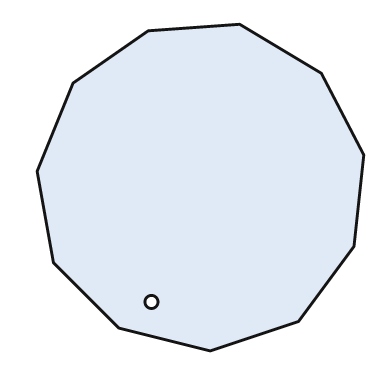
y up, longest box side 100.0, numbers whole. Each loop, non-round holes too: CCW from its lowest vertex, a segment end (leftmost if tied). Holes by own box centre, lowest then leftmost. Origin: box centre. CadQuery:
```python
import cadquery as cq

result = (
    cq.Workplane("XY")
    .moveTo(3.0, -50.0)
    .lineTo(30.0, -41.0)
    .lineTo(47.0, -18.0)
    .lineTo(50.0, 10.0)
    .lineTo(37.0, 35.0)
    .lineTo(12.0, 50.0)
    .lineTo(-16.0, 48.0)
    .lineTo(-39.0, 32.0)
    .lineTo(-50.0, 5.0)
    .lineTo(-45.0, -23.0)
    .lineTo(-25.0, -43.0)
    .close()
    .moveTo(-15.0, -35.0)
    .circle(2.0)
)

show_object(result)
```